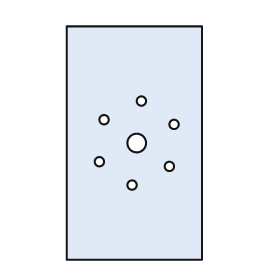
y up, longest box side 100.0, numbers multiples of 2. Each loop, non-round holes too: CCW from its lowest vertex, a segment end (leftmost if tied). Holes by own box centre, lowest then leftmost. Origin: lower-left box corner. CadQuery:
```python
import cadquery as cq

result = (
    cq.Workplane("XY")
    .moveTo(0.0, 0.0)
    .lineTo(58.0, 0.0)
    .lineTo(58.0, 100.0)
    .lineTo(0.0, 100.0)
    .close()
    .moveTo(28.0, 32.0)
    .circle(2.0)
    .moveTo(44.0, 40.0)
    .circle(2.0)
    .moveTo(14.0, 42.0)
    .circle(2.0)
    .moveTo(30.0, 50.0)
    .circle(4.0)
    .moveTo(46.0, 58.0)
    .circle(2.0)
    .moveTo(16.0, 60.0)
    .circle(2.0)
    .moveTo(32.0, 68.0)
    .circle(2.0)
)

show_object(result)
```